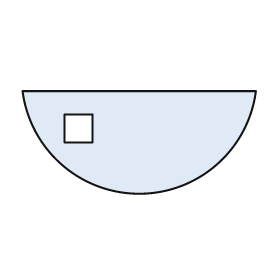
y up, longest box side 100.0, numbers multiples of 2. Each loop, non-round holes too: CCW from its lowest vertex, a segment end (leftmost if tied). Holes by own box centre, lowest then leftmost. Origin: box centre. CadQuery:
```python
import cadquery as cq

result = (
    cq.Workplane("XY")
    .moveTo(-50.0, 22.0)
    .threePointArc((0.0, -22.0), (50.0, 22.0))
    .close()
    .moveTo(-32.0, 0.0)
    .lineTo(-20.0, 0.0)
    .lineTo(-20.0, 12.0)
    .lineTo(-32.0, 12.0)
    .close()
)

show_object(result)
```